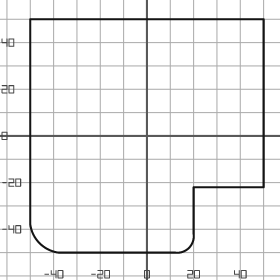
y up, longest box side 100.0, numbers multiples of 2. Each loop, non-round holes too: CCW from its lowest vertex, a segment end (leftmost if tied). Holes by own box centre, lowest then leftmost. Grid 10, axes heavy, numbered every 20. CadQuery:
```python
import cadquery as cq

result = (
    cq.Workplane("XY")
    .moveTo(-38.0, -50.0)
    .lineTo(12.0, -50.0)
    .threePointArc((18.0, -48.0), (20.0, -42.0))
    .lineTo(20.0, -22.0)
    .lineTo(50.0, -22.0)
    .lineTo(50.0, 50.0)
    .lineTo(-50.0, 50.0)
    .lineTo(-50.0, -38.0)
    .threePointArc((-46.0, -46.0), (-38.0, -50.0))
    .close()
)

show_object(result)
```